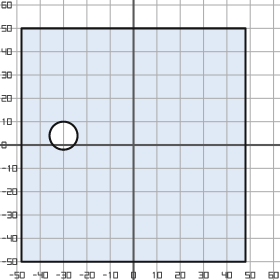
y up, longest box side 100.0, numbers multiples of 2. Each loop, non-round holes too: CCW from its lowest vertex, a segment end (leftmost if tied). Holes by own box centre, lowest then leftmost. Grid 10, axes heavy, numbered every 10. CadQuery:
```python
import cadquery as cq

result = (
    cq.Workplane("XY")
    .moveTo(-48.0, -50.0)
    .lineTo(48.0, -50.0)
    .lineTo(48.0, 50.0)
    .lineTo(-48.0, 50.0)
    .close()
    .moveTo(-30.0, 4.0)
    .circle(6.0)
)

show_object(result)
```